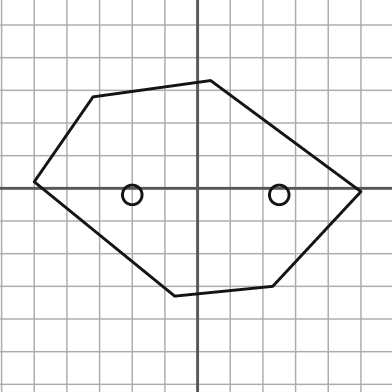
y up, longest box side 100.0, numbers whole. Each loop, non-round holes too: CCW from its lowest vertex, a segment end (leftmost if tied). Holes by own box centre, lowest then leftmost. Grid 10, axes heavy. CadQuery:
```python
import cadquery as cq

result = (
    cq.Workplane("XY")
    .moveTo(-7.0, -33.0)
    .lineTo(23.0, -30.0)
    .lineTo(50.0, -1.0)
    .lineTo(4.0, 33.0)
    .lineTo(-32.0, 28.0)
    .lineTo(-50.0, 2.0)
    .close()
    .moveTo(-20.0, -2.0)
    .circle(3.0)
    .moveTo(25.0, -2.0)
    .circle(3.0)
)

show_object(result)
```